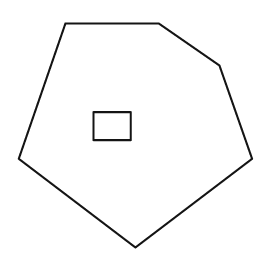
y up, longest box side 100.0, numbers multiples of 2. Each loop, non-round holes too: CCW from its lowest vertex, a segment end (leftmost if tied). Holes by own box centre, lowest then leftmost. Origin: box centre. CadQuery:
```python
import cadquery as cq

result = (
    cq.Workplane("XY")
    .moveTo(0.0, -48.0)
    .lineTo(50.0, -10.0)
    .lineTo(36.0, 30.0)
    .lineTo(10.0, 48.0)
    .lineTo(-30.0, 48.0)
    .lineTo(-50.0, -10.0)
    .close()
    .moveTo(-18.0, -2.0)
    .lineTo(-2.0, -2.0)
    .lineTo(-2.0, 10.0)
    .lineTo(-18.0, 10.0)
    .close()
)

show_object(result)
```